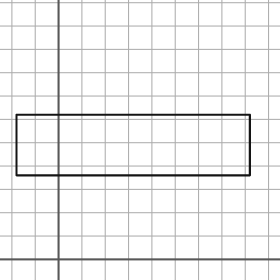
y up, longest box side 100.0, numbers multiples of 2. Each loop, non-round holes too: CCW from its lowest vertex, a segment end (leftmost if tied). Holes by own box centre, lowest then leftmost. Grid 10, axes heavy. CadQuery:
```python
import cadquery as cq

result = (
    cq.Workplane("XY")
    .moveTo(-18.0, 36.0)
    .lineTo(82.0, 36.0)
    .lineTo(82.0, 62.0)
    .lineTo(-18.0, 62.0)
    .close()
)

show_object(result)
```